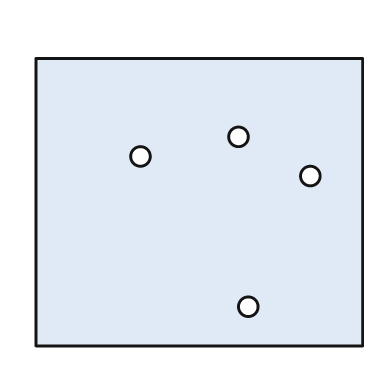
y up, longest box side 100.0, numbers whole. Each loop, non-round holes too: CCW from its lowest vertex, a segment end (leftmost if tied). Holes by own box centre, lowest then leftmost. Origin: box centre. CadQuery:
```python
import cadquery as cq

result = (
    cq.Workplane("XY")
    .moveTo(-50.0, -44.0)
    .lineTo(50.0, -44.0)
    .lineTo(50.0, 44.0)
    .lineTo(-50.0, 44.0)
    .close()
    .moveTo(15.0, -32.0)
    .circle(3.0)
    .moveTo(34.0, 8.0)
    .circle(3.0)
    .moveTo(-18.0, 14.0)
    .circle(3.0)
    .moveTo(12.0, 20.0)
    .circle(3.0)
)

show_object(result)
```